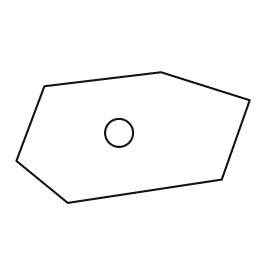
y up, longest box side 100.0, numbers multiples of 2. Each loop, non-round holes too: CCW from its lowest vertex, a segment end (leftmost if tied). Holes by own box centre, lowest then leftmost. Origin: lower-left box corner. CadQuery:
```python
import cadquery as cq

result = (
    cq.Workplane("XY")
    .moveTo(22.0, 0.0)
    .lineTo(88.0, 10.0)
    .lineTo(100.0, 44.0)
    .lineTo(62.0, 56.0)
    .lineTo(12.0, 50.0)
    .lineTo(0.0, 18.0)
    .close()
    .moveTo(44.0, 30.0)
    .circle(6.0)
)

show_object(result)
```